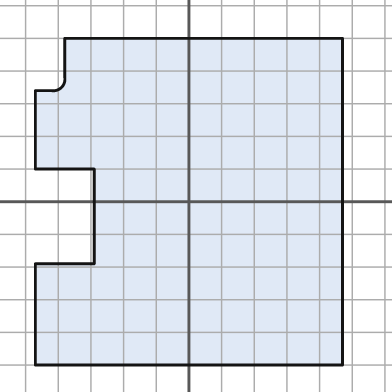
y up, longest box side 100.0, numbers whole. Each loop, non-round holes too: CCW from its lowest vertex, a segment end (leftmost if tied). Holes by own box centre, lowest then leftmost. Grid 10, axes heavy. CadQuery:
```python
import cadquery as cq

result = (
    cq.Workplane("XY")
    .moveTo(-47.0, -50.0)
    .lineTo(47.0, -50.0)
    .lineTo(47.0, 50.0)
    .lineTo(-38.0, 50.0)
    .lineTo(-38.0, 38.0)
    .threePointArc((-39.0, 35.0), (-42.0, 34.0))
    .lineTo(-47.0, 34.0)
    .lineTo(-47.0, 10.0)
    .lineTo(-29.0, 10.0)
    .lineTo(-29.0, -19.0)
    .lineTo(-47.0, -19.0)
    .close()
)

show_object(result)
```